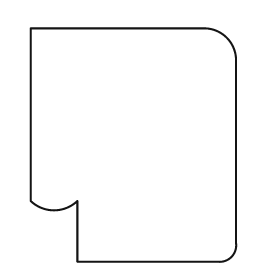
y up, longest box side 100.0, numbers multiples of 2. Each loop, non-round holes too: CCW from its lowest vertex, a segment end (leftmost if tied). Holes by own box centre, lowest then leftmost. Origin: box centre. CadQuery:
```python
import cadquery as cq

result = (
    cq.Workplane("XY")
    .moveTo(-24.0, -50.0)
    .lineTo(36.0, -50.0)
    .threePointArc((42.0, -48.0), (44.0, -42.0))
    .lineTo(44.0, 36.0)
    .threePointArc((40.0, 46.0), (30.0, 50.0))
    .lineTo(-44.0, 50.0)
    .lineTo(-44.0, -24.0)
    .threePointArc((-34.0, -28.0), (-24.0, -24.0))
    .close()
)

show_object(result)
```